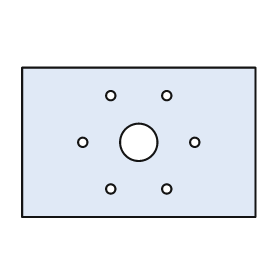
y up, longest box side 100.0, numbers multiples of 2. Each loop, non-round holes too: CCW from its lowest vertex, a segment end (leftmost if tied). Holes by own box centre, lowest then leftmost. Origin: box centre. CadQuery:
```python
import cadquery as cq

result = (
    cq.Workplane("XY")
    .moveTo(-50.0, -32.0)
    .lineTo(50.0, -32.0)
    .lineTo(50.0, 32.0)
    .lineTo(-50.0, 32.0)
    .close()
    .moveTo(-12.0, -20.0)
    .circle(2.0)
    .moveTo(12.0, -20.0)
    .circle(2.0)
    .moveTo(-24.0, 0.0)
    .circle(2.0)
    .moveTo(0.0, 0.0)
    .circle(8.0)
    .moveTo(24.0, 0.0)
    .circle(2.0)
    .moveTo(-12.0, 20.0)
    .circle(2.0)
    .moveTo(12.0, 20.0)
    .circle(2.0)
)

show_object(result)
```